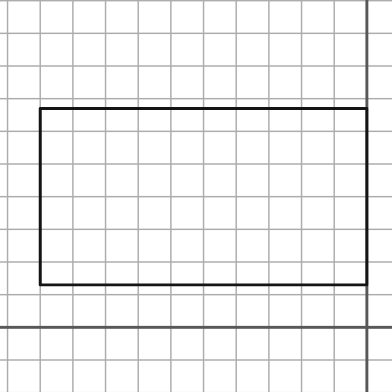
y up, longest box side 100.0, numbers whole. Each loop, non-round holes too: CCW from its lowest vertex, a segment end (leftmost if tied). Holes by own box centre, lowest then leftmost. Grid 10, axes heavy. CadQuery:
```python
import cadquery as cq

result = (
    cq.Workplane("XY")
    .moveTo(-100.0, 13.0)
    .lineTo(0.0, 13.0)
    .lineTo(0.0, 67.0)
    .lineTo(-100.0, 67.0)
    .close()
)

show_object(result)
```